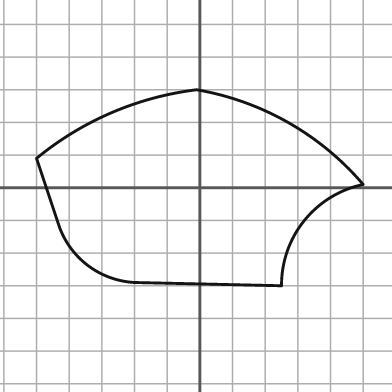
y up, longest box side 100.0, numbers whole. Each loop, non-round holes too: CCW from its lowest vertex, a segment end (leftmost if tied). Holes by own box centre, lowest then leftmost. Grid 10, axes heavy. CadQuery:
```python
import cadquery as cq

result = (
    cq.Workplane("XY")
    .moveTo(25.0, -30.0)
    .threePointArc((32.0, -10.0), (50.0, 1.0))
    .threePointArc((27.0, 20.0), (-1.0, 30.0))
    .threePointArc((-27.0, 23.0), (-50.0, 9.0))
    .lineTo(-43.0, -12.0)
    .threePointArc((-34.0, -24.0), (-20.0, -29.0))
    .close()
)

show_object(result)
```